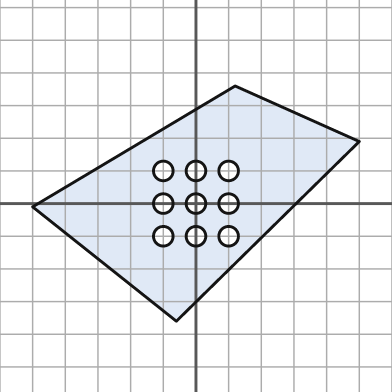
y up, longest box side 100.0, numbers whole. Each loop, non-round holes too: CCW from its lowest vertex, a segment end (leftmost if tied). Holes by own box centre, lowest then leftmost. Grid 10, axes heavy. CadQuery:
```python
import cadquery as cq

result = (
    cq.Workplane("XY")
    .moveTo(-6.0, -36.0)
    .lineTo(50.0, 19.0)
    .lineTo(12.0, 36.0)
    .lineTo(-50.0, -1.0)
    .close()
    .moveTo(-10.0, -10.0)
    .circle(3.0)
    .moveTo(0.0, -10.0)
    .circle(3.0)
    .moveTo(10.0, -10.0)
    .circle(3.0)
    .moveTo(-10.0, 0.0)
    .circle(3.0)
    .moveTo(0.0, 0.0)
    .circle(3.0)
    .moveTo(10.0, 0.0)
    .circle(3.0)
    .moveTo(-10.0, 10.0)
    .circle(3.0)
    .moveTo(0.0, 10.0)
    .circle(3.0)
    .moveTo(10.0, 10.0)
    .circle(3.0)
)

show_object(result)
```